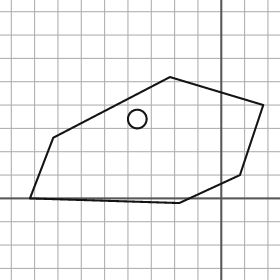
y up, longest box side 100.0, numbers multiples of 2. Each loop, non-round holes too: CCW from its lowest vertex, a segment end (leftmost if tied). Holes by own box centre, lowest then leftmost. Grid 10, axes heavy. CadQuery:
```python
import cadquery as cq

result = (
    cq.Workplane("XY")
    .moveTo(-18.0, -2.0)
    .lineTo(8.0, 10.0)
    .lineTo(18.0, 40.0)
    .lineTo(-22.0, 52.0)
    .lineTo(-72.0, 26.0)
    .lineTo(-82.0, 0.0)
    .close()
    .moveTo(-36.0, 34.0)
    .circle(4.0)
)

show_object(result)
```